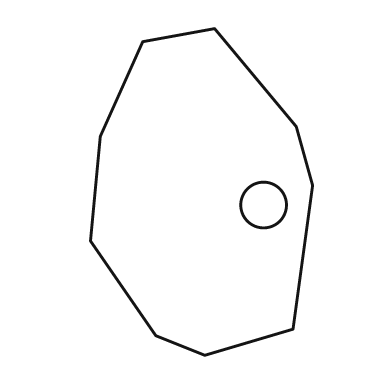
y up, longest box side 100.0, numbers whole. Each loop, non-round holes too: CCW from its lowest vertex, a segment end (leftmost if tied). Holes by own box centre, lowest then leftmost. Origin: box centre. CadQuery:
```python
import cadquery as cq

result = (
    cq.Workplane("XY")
    .moveTo(1.0, -50.0)
    .lineTo(28.0, -42.0)
    .lineTo(34.0, 2.0)
    .lineTo(29.0, 20.0)
    .lineTo(4.0, 50.0)
    .lineTo(-18.0, 46.0)
    .lineTo(-31.0, 17.0)
    .lineTo(-34.0, -15.0)
    .lineTo(-14.0, -44.0)
    .close()
    .moveTo(19.0, -4.0)
    .circle(7.0)
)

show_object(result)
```